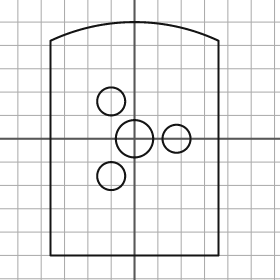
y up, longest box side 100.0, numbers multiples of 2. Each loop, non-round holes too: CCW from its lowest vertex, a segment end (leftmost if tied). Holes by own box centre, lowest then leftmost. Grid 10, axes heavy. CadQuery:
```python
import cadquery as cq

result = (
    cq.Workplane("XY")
    .moveTo(-36.0, -50.0)
    .lineTo(36.0, -50.0)
    .lineTo(36.0, 42.0)
    .threePointArc((0.0, 50.0), (-36.0, 42.0))
    .close()
    .moveTo(-10.0, -16.0)
    .circle(6.0)
    .moveTo(0.0, 0.0)
    .circle(8.0)
    .moveTo(18.0, 0.0)
    .circle(6.0)
    .moveTo(-10.0, 16.0)
    .circle(6.0)
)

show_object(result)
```